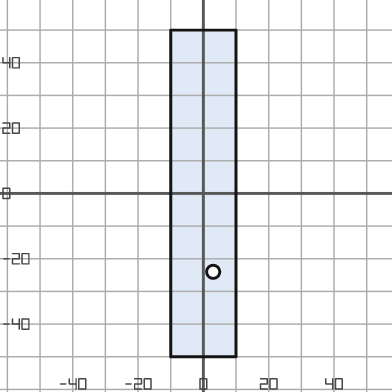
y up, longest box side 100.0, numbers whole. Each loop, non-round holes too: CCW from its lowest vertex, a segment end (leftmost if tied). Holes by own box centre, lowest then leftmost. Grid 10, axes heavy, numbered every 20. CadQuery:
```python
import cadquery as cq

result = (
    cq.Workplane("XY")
    .moveTo(-10.0, -50.0)
    .lineTo(10.0, -50.0)
    .lineTo(10.0, 50.0)
    .lineTo(-10.0, 50.0)
    .close()
    .moveTo(3.0, -24.0)
    .circle(2.0)
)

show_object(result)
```